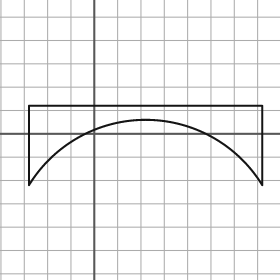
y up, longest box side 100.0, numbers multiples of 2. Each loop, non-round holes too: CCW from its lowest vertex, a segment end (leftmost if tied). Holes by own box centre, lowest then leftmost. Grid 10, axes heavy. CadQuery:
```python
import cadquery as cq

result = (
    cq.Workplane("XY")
    .moveTo(-28.0, -22.0)
    .threePointArc((22.0, 6.0), (72.0, -22.0))
    .lineTo(72.0, 12.0)
    .lineTo(-28.0, 12.0)
    .close()
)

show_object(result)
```